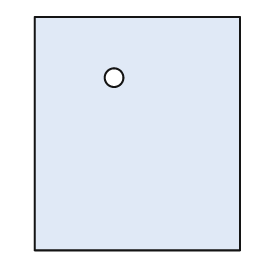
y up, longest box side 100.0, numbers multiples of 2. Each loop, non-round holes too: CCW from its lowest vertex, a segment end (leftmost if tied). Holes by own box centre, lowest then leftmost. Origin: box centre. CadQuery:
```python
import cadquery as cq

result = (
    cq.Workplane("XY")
    .moveTo(-44.0, -50.0)
    .lineTo(44.0, -50.0)
    .lineTo(44.0, 50.0)
    .lineTo(-44.0, 50.0)
    .close()
    .moveTo(-10.0, 24.0)
    .circle(4.0)
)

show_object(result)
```